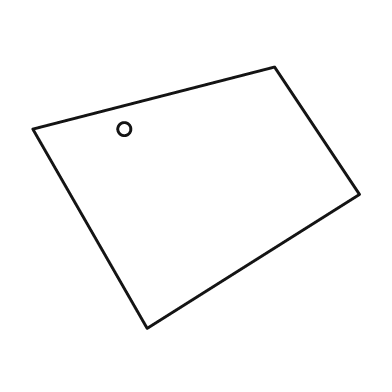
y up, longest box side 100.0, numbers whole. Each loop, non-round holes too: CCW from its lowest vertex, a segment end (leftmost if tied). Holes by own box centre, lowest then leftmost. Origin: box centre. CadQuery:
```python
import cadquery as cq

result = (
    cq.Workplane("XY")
    .moveTo(-15.0, -40.0)
    .lineTo(50.0, 1.0)
    .lineTo(24.0, 40.0)
    .lineTo(-50.0, 21.0)
    .close()
    .moveTo(-22.0, 21.0)
    .circle(2.0)
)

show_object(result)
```